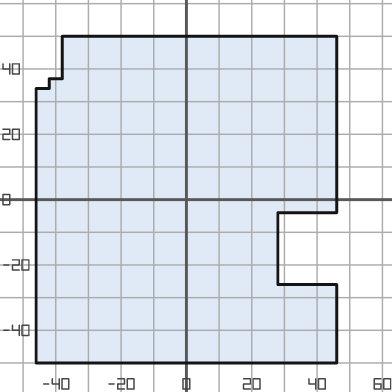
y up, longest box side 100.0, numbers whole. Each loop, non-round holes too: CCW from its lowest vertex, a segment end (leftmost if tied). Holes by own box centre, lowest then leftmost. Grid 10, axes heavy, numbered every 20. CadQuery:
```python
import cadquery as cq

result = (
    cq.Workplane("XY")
    .moveTo(-46.0, -50.0)
    .lineTo(46.0, -50.0)
    .lineTo(46.0, -26.0)
    .lineTo(28.0, -26.0)
    .lineTo(28.0, -4.0)
    .lineTo(46.0, -4.0)
    .lineTo(46.0, 50.0)
    .lineTo(-38.0, 50.0)
    .lineTo(-38.0, 37.0)
    .lineTo(-42.0, 37.0)
    .lineTo(-42.0, 34.0)
    .lineTo(-46.0, 34.0)
    .close()
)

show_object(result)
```